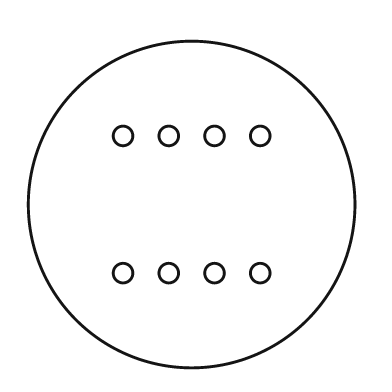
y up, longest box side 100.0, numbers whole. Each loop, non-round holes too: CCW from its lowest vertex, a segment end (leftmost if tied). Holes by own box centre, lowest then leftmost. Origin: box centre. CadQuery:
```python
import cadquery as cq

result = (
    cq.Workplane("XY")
    .moveTo(0.0, 0.0)
    .circle(50.0)
    .moveTo(-21.0, -21.0)
    .circle(3.0)
    .moveTo(-7.0, -21.0)
    .circle(3.0)
    .moveTo(7.0, -21.0)
    .circle(3.0)
    .moveTo(21.0, -21.0)
    .circle(3.0)
    .moveTo(-21.0, 21.0)
    .circle(3.0)
    .moveTo(-7.0, 21.0)
    .circle(3.0)
    .moveTo(7.0, 21.0)
    .circle(3.0)
    .moveTo(21.0, 21.0)
    .circle(3.0)
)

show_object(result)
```